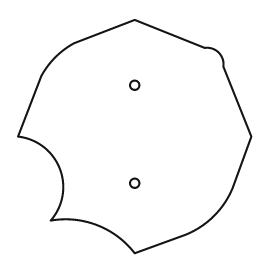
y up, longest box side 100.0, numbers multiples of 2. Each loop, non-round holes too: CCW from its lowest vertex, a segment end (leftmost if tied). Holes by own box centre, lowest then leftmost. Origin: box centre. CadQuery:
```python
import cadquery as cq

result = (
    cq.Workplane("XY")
    .moveTo(0.0, -50.0)
    .lineTo(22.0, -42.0)
    .threePointArc((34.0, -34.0), (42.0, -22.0))
    .lineTo(50.0, 0.0)
    .lineTo(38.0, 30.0)
    .threePointArc((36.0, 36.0), (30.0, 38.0))
    .lineTo(0.0, 50.0)
    .lineTo(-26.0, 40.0)
    .threePointArc((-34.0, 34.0), (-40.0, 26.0))
    .lineTo(-50.0, 0.0)
    .threePointArc((-32.0, -14.0), (-36.0, -36.0))
    .threePointArc((-16.0, -38.0), (0.0, -50.0))
    .close()
    .moveTo(0.0, -20.0)
    .circle(2.0)
    .moveTo(0.0, 22.0)
    .circle(2.0)
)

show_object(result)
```